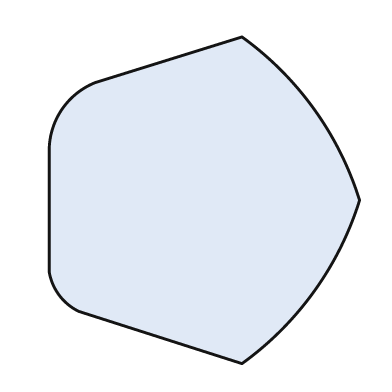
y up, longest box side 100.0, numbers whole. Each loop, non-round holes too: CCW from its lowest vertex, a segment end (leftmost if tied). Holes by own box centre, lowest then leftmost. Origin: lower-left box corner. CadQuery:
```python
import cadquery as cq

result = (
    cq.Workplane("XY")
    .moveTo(59.0, 0.0)
    .threePointArc((81.0, 22.0), (95.0, 50.0))
    .threePointArc((81.0, 78.0), (59.0, 100.0))
    .lineTo(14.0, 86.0)
    .threePointArc((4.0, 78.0), (0.0, 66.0))
    .lineTo(0.0, 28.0)
    .threePointArc((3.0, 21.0), (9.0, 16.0))
    .close()
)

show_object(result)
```